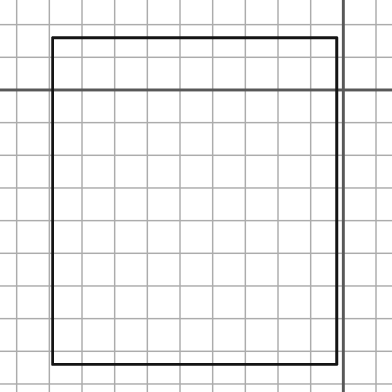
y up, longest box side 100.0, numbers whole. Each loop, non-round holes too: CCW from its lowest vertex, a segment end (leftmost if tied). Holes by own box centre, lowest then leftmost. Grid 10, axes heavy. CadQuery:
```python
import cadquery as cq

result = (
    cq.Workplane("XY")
    .moveTo(-89.0, -84.0)
    .lineTo(-2.0, -84.0)
    .lineTo(-2.0, 16.0)
    .lineTo(-89.0, 16.0)
    .close()
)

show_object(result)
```